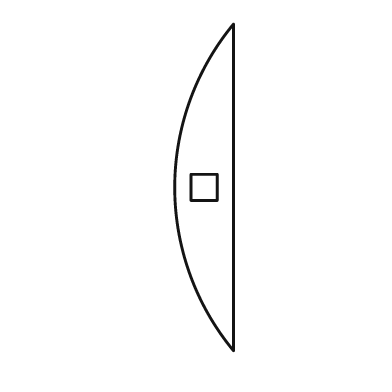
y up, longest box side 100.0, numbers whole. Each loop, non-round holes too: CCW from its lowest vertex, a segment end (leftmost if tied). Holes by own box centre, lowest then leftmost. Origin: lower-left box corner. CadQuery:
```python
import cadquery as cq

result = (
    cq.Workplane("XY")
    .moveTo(18.0, 0.0)
    .lineTo(18.0, 100.0)
    .threePointArc((0.0, 50.0), (18.0, 0.0))
    .close()
    .moveTo(5.0, 46.0)
    .lineTo(13.0, 46.0)
    .lineTo(13.0, 54.0)
    .lineTo(5.0, 54.0)
    .close()
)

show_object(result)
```